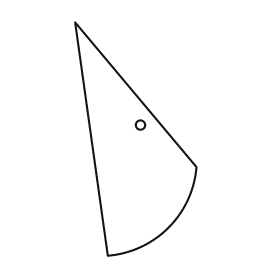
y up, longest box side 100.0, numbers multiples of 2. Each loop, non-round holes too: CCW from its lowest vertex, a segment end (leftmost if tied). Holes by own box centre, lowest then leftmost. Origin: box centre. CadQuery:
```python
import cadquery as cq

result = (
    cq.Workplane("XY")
    .moveTo(-12.0, -50.0)
    .threePointArc((14.0, -38.0), (26.0, -12.0))
    .lineTo(-26.0, 50.0)
    .close()
    .moveTo(2.0, 6.0)
    .circle(2.0)
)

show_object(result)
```